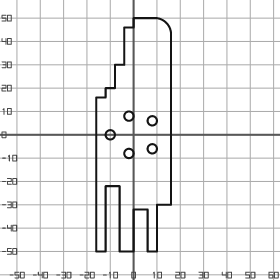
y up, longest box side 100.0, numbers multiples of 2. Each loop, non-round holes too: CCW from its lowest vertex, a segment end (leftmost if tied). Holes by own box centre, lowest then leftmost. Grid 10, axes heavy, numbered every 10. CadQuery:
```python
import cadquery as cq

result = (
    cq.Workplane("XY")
    .moveTo(-16.0, -50.0)
    .lineTo(-12.0, -50.0)
    .lineTo(-12.0, -22.0)
    .lineTo(-6.0, -22.0)
    .lineTo(-6.0, -50.0)
    .lineTo(0.0, -50.0)
    .lineTo(0.0, -32.0)
    .lineTo(6.0, -32.0)
    .lineTo(6.0, -50.0)
    .lineTo(10.0, -50.0)
    .lineTo(10.0, -30.0)
    .lineTo(16.0, -30.0)
    .lineTo(16.0, 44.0)
    .threePointArc((14.0, 48.0), (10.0, 50.0))
    .lineTo(0.0, 50.0)
    .lineTo(0.0, 46.0)
    .lineTo(-4.0, 46.0)
    .lineTo(-4.0, 30.0)
    .lineTo(-8.0, 30.0)
    .lineTo(-8.0, 20.0)
    .lineTo(-12.0, 20.0)
    .lineTo(-12.0, 16.0)
    .lineTo(-16.0, 16.0)
    .close()
    .moveTo(-2.0, -8.0)
    .circle(2.0)
    .moveTo(8.0, -6.0)
    .circle(2.0)
    .moveTo(-10.0, 0.0)
    .circle(2.0)
    .moveTo(8.0, 6.0)
    .circle(2.0)
    .moveTo(-2.0, 8.0)
    .circle(2.0)
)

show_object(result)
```